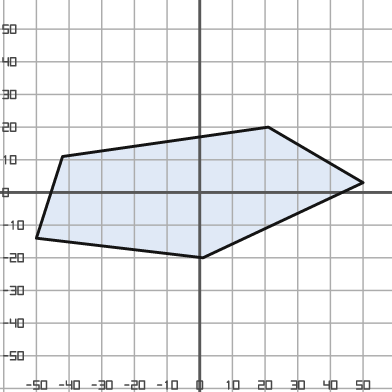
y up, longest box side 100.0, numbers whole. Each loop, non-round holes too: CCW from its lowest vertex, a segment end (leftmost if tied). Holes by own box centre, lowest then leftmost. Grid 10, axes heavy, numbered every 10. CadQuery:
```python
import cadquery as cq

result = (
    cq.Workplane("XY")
    .moveTo(1.0, -20.0)
    .lineTo(50.0, 3.0)
    .lineTo(21.0, 20.0)
    .lineTo(-42.0, 11.0)
    .lineTo(-50.0, -14.0)
    .close()
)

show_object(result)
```